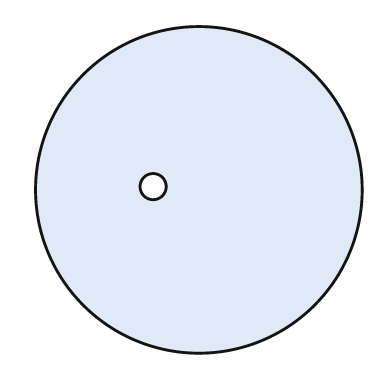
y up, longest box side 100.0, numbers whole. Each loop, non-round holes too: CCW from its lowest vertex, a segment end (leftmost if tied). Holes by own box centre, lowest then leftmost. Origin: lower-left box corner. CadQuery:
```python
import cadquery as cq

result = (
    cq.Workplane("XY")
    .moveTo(50.0, 50.0)
    .circle(50.0)
    .moveTo(36.0, 51.0)
    .circle(4.0)
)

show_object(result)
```